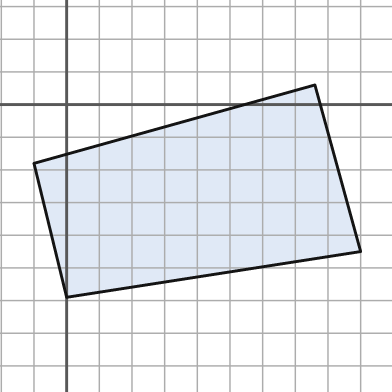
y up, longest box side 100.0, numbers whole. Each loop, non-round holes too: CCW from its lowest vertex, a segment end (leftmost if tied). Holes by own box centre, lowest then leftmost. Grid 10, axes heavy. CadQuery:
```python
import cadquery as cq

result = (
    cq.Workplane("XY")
    .moveTo(0.0, -59.0)
    .lineTo(90.0, -45.0)
    .lineTo(76.0, 6.0)
    .lineTo(-10.0, -18.0)
    .close()
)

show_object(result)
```